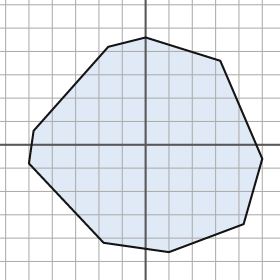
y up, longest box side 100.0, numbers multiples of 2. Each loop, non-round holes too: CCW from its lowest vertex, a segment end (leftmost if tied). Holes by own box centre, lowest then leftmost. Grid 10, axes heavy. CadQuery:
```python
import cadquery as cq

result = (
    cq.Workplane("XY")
    .moveTo(10.0, -46.0)
    .lineTo(42.0, -34.0)
    .lineTo(50.0, -6.0)
    .lineTo(32.0, 36.0)
    .lineTo(0.0, 46.0)
    .lineTo(-16.0, 42.0)
    .lineTo(-48.0, 6.0)
    .lineTo(-50.0, -8.0)
    .lineTo(-18.0, -42.0)
    .close()
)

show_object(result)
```